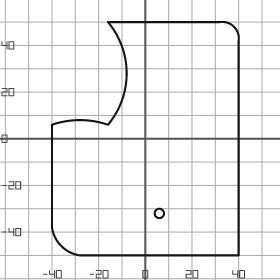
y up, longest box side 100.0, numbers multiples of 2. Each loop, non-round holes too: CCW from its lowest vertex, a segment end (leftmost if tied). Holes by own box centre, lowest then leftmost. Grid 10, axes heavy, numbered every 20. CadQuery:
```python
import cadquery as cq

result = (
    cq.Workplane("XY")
    .moveTo(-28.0, -50.0)
    .lineTo(40.0, -50.0)
    .lineTo(40.0, 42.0)
    .threePointArc((38.0, 48.0), (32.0, 50.0))
    .lineTo(-16.0, 50.0)
    .threePointArc((-8.0, 28.0), (-16.0, 6.0))
    .threePointArc((-28.0, 8.0), (-40.0, 6.0))
    .lineTo(-40.0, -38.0)
    .threePointArc((-36.0, -46.0), (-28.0, -50.0))
    .close()
    .moveTo(6.0, -32.0)
    .circle(2.0)
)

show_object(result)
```